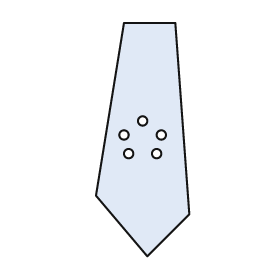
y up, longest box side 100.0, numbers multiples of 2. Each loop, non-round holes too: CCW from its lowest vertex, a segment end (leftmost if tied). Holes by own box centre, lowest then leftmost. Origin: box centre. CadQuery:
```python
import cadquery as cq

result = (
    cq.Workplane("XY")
    .moveTo(2.0, -50.0)
    .lineTo(20.0, -32.0)
    .lineTo(14.0, 50.0)
    .lineTo(-8.0, 50.0)
    .lineTo(-20.0, -24.0)
    .close()
    .moveTo(-6.0, -6.0)
    .circle(2.0)
    .moveTo(6.0, -6.0)
    .circle(2.0)
    .moveTo(-8.0, 2.0)
    .circle(2.0)
    .moveTo(8.0, 2.0)
    .circle(2.0)
    .moveTo(0.0, 8.0)
    .circle(2.0)
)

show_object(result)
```